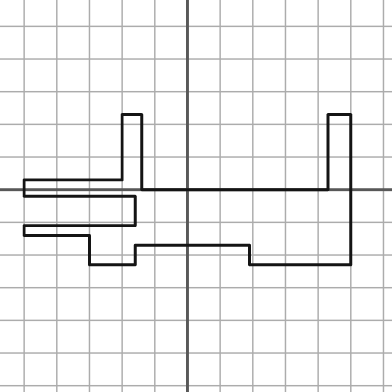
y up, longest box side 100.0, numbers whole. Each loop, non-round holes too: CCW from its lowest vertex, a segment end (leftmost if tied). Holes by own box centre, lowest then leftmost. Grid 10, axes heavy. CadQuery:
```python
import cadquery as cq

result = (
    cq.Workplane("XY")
    .moveTo(-30.0, -23.0)
    .lineTo(-16.0, -23.0)
    .lineTo(-16.0, -17.0)
    .lineTo(19.0, -17.0)
    .lineTo(19.0, -23.0)
    .lineTo(50.0, -23.0)
    .lineTo(50.0, 23.0)
    .lineTo(43.0, 23.0)
    .lineTo(43.0, 0.0)
    .lineTo(-14.0, 0.0)
    .lineTo(-14.0, 23.0)
    .lineTo(-20.0, 23.0)
    .lineTo(-20.0, 3.0)
    .lineTo(-50.0, 3.0)
    .lineTo(-50.0, -2.0)
    .lineTo(-16.0, -2.0)
    .lineTo(-16.0, -11.0)
    .lineTo(-50.0, -11.0)
    .lineTo(-50.0, -14.0)
    .lineTo(-30.0, -14.0)
    .close()
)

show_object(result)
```